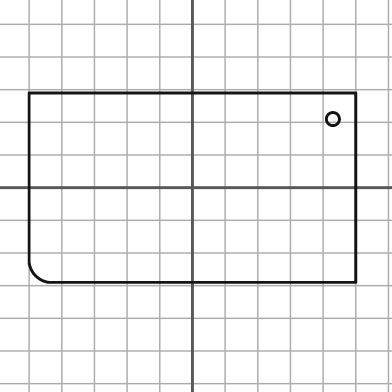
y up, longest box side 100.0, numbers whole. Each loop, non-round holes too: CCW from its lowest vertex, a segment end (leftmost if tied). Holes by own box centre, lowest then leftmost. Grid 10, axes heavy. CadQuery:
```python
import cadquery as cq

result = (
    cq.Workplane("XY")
    .moveTo(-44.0, -29.0)
    .lineTo(50.0, -29.0)
    .lineTo(50.0, 29.0)
    .lineTo(-50.0, 29.0)
    .lineTo(-50.0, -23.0)
    .threePointArc((-48.0, -27.0), (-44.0, -29.0))
    .close()
    .moveTo(43.0, 21.0)
    .circle(2.0)
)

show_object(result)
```